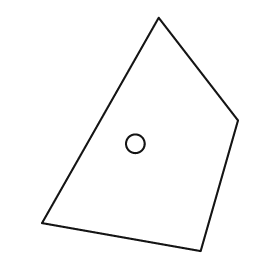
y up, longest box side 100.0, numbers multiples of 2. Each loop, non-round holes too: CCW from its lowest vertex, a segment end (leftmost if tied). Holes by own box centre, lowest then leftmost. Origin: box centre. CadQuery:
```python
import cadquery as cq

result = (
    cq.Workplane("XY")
    .moveTo(26.0, -50.0)
    .lineTo(42.0, 6.0)
    .lineTo(8.0, 50.0)
    .lineTo(-42.0, -38.0)
    .close()
    .moveTo(-2.0, -4.0)
    .circle(4.0)
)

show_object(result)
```